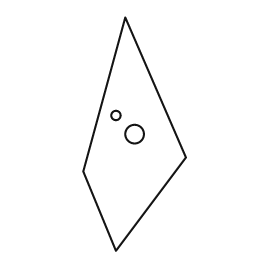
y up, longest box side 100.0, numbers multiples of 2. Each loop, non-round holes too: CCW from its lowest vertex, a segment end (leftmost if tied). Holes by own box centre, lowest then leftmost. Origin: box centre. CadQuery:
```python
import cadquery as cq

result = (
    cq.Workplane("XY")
    .moveTo(-8.0, -50.0)
    .lineTo(22.0, -10.0)
    .lineTo(-4.0, 50.0)
    .lineTo(-22.0, -16.0)
    .close()
    .moveTo(0.0, 0.0)
    .circle(4.0)
    .moveTo(-8.0, 8.0)
    .circle(2.0)
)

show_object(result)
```